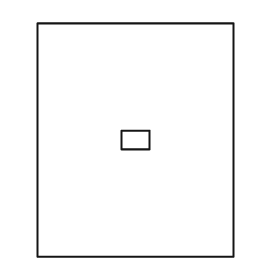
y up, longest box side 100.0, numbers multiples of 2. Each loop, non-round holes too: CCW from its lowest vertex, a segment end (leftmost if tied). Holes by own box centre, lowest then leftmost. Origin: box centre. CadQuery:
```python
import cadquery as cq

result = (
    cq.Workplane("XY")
    .moveTo(-42.0, -50.0)
    .lineTo(42.0, -50.0)
    .lineTo(42.0, 50.0)
    .lineTo(-42.0, 50.0)
    .close()
    .moveTo(-6.0, -4.0)
    .lineTo(6.0, -4.0)
    .lineTo(6.0, 4.0)
    .lineTo(-6.0, 4.0)
    .close()
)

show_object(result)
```